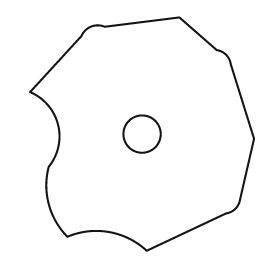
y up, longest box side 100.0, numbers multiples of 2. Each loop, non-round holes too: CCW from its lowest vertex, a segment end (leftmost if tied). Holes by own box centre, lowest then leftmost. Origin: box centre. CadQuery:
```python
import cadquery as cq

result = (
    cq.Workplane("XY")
    .moveTo(2.0, -50.0)
    .lineTo(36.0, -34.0)
    .threePointArc((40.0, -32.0), (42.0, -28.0))
    .lineTo(48.0, -2.0)
    .lineTo(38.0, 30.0)
    .threePointArc((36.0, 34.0), (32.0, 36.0))
    .lineTo(16.0, 50.0)
    .lineTo(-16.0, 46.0)
    .threePointArc((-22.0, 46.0), (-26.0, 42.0))
    .lineTo(-48.0, 18.0)
    .threePointArc((-36.0, 4.0), (-40.0, -14.0))
    .threePointArc((-40.0, -30.0), (-32.0, -44.0))
    .threePointArc((-14.0, -42.0), (2.0, -50.0))
    .close()
    .moveTo(0.0, 0.0)
    .circle(8.0)
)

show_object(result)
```